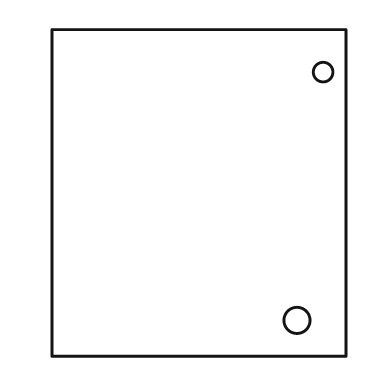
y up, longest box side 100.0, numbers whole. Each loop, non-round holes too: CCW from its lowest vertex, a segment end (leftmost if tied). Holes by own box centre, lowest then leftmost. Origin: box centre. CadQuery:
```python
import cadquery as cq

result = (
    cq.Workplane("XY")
    .moveTo(-45.0, -50.0)
    .lineTo(45.0, -50.0)
    .lineTo(45.0, 50.0)
    .lineTo(-45.0, 50.0)
    .close()
    .moveTo(30.0, -39.0)
    .circle(4.0)
    .moveTo(38.0, 37.0)
    .circle(3.0)
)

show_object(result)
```